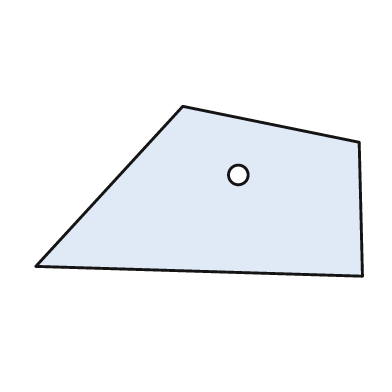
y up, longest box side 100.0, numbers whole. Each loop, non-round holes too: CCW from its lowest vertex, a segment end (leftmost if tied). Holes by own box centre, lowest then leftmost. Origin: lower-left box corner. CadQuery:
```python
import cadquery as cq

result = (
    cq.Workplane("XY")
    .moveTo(100.0, 0.0)
    .lineTo(99.0, 41.0)
    .lineTo(45.0, 52.0)
    .lineTo(0.0, 3.0)
    .close()
    .moveTo(62.0, 31.0)
    .circle(3.0)
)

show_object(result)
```